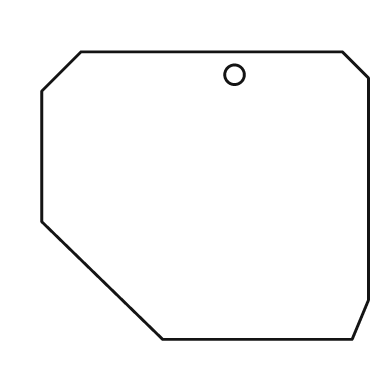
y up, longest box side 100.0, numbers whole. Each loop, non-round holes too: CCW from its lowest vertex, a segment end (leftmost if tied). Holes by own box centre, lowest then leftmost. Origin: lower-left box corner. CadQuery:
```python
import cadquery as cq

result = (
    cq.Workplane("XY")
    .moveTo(37.0, 0.0)
    .lineTo(95.0, 0.0)
    .lineTo(100.0, 12.0)
    .lineTo(100.0, 80.0)
    .lineTo(92.0, 88.0)
    .lineTo(12.0, 88.0)
    .lineTo(0.0, 76.0)
    .lineTo(0.0, 36.0)
    .close()
    .moveTo(59.0, 81.0)
    .circle(3.0)
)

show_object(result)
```